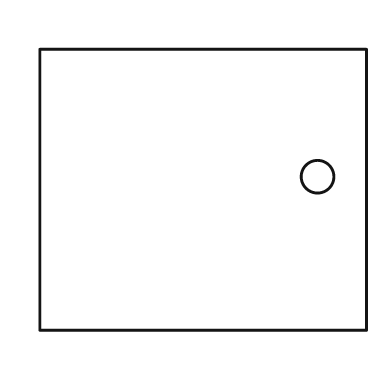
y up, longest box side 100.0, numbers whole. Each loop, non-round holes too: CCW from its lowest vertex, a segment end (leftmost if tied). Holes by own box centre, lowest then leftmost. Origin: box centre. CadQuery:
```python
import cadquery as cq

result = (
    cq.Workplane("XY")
    .moveTo(-50.0, -43.0)
    .lineTo(50.0, -43.0)
    .lineTo(50.0, 43.0)
    .lineTo(-50.0, 43.0)
    .close()
    .moveTo(35.0, 4.0)
    .circle(5.0)
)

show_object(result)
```